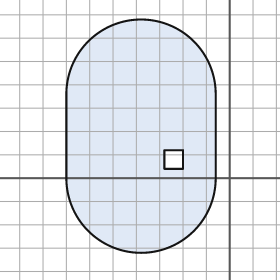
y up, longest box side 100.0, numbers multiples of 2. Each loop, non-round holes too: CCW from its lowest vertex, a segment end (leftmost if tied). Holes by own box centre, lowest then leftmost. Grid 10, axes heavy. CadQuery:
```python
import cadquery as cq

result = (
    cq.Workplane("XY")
    .moveTo(-70.0, 0.0)
    .threePointArc((-38.0, -32.0), (-6.0, 0.0))
    .lineTo(-6.0, 36.0)
    .threePointArc((-38.0, 68.0), (-70.0, 36.0))
    .close()
    .moveTo(-28.0, 4.0)
    .lineTo(-20.0, 4.0)
    .lineTo(-20.0, 12.0)
    .lineTo(-28.0, 12.0)
    .close()
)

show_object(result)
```